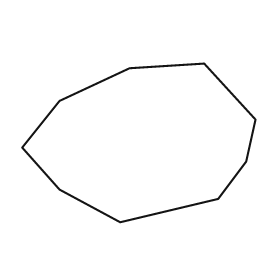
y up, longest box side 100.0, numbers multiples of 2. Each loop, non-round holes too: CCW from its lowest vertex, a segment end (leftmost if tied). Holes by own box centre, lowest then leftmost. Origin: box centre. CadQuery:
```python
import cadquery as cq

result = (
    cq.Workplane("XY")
    .moveTo(-8.0, -34.0)
    .lineTo(34.0, -24.0)
    .lineTo(46.0, -8.0)
    .lineTo(50.0, 10.0)
    .lineTo(28.0, 34.0)
    .lineTo(-4.0, 32.0)
    .lineTo(-34.0, 18.0)
    .lineTo(-50.0, -2.0)
    .lineTo(-34.0, -20.0)
    .close()
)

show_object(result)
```